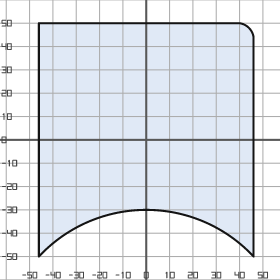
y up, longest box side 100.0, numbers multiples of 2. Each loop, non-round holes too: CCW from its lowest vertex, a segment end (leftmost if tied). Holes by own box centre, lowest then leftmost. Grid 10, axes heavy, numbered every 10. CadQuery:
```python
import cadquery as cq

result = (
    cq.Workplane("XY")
    .moveTo(-46.0, -50.0)
    .threePointArc((0.0, -30.0), (46.0, -50.0))
    .lineTo(46.0, 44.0)
    .threePointArc((44.0, 48.0), (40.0, 50.0))
    .lineTo(-46.0, 50.0)
    .close()
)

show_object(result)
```